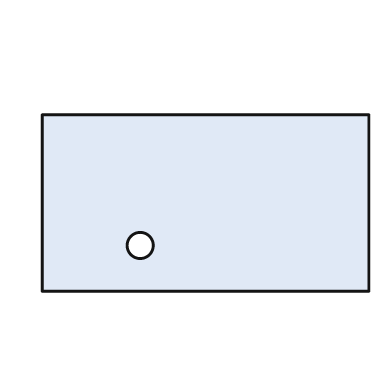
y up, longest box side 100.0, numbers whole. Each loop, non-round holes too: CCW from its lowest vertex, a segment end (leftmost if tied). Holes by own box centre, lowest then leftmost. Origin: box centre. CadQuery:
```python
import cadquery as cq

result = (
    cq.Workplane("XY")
    .moveTo(-50.0, -27.0)
    .lineTo(50.0, -27.0)
    .lineTo(50.0, 27.0)
    .lineTo(-50.0, 27.0)
    .close()
    .moveTo(-20.0, -13.0)
    .circle(4.0)
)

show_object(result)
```